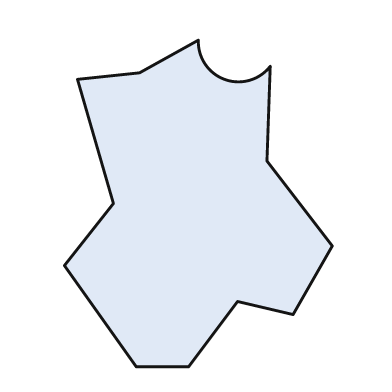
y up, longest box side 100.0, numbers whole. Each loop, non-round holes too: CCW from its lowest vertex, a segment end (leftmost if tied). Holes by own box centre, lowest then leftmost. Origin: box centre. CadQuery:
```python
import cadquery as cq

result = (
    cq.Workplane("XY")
    .moveTo(-19.0, -50.0)
    .lineTo(-3.0, -50.0)
    .lineTo(12.0, -30.0)
    .lineTo(29.0, -34.0)
    .lineTo(41.0, -13.0)
    .lineTo(21.0, 13.0)
    .lineTo(22.0, 42.0)
    .threePointArc((8.0, 38.0), (0.0, 50.0))
    .lineTo(-18.0, 40.0)
    .lineTo(-37.0, 38.0)
    .lineTo(-26.0, 0.0)
    .lineTo(-41.0, -19.0)
    .close()
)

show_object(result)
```